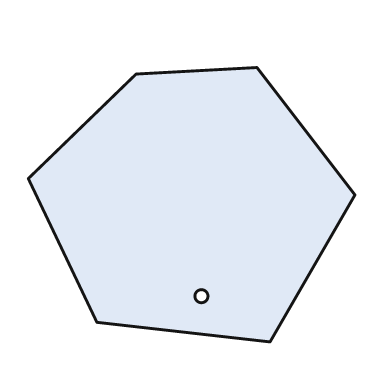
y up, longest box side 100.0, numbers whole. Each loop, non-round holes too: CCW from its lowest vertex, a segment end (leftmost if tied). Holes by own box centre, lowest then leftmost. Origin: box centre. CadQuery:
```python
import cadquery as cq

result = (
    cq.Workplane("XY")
    .moveTo(24.0, -42.0)
    .lineTo(50.0, 3.0)
    .lineTo(20.0, 42.0)
    .lineTo(-17.0, 40.0)
    .lineTo(-50.0, 8.0)
    .lineTo(-29.0, -36.0)
    .close()
    .moveTo(3.0, -28.0)
    .circle(2.0)
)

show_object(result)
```